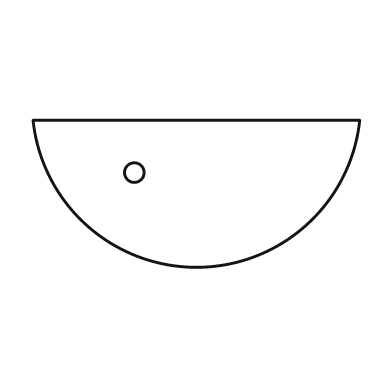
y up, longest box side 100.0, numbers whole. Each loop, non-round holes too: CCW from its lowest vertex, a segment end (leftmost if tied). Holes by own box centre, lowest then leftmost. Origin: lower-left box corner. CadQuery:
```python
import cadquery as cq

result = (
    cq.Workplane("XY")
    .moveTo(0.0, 45.0)
    .threePointArc((50.0, 0.0), (100.0, 45.0))
    .close()
    .moveTo(31.0, 29.0)
    .circle(3.0)
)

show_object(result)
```